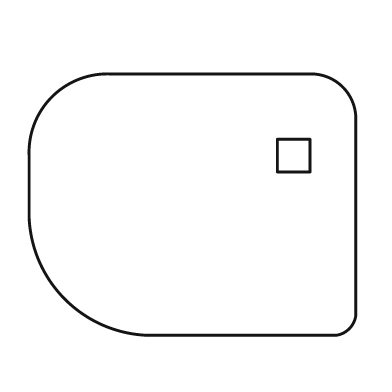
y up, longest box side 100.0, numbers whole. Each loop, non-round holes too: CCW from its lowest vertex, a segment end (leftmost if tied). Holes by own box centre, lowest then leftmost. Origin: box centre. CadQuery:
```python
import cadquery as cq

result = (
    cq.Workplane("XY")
    .moveTo(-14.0, -40.0)
    .lineTo(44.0, -40.0)
    .threePointArc((48.0, -38.0), (50.0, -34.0))
    .lineTo(50.0, 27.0)
    .threePointArc((46.0, 36.0), (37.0, 40.0))
    .lineTo(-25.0, 40.0)
    .threePointArc((-43.0, 33.0), (-50.0, 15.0))
    .lineTo(-50.0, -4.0)
    .threePointArc((-39.0, -29.0), (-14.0, -40.0))
    .close()
    .moveTo(26.0, 10.0)
    .lineTo(36.0, 10.0)
    .lineTo(36.0, 20.0)
    .lineTo(26.0, 20.0)
    .close()
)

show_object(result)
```